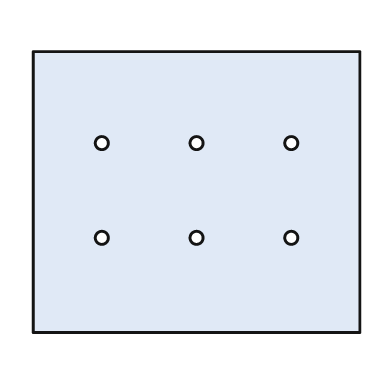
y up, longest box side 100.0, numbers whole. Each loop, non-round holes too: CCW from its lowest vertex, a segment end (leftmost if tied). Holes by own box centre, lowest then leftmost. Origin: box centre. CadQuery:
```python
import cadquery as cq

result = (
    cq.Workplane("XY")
    .moveTo(-50.0, -43.0)
    .lineTo(50.0, -43.0)
    .lineTo(50.0, 43.0)
    .lineTo(-50.0, 43.0)
    .close()
    .moveTo(-29.0, -14.0)
    .circle(2.0)
    .moveTo(0.0, -14.0)
    .circle(2.0)
    .moveTo(29.0, -14.0)
    .circle(2.0)
    .moveTo(-29.0, 15.0)
    .circle(2.0)
    .moveTo(0.0, 15.0)
    .circle(2.0)
    .moveTo(29.0, 15.0)
    .circle(2.0)
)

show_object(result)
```